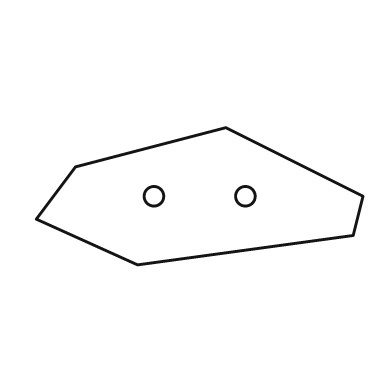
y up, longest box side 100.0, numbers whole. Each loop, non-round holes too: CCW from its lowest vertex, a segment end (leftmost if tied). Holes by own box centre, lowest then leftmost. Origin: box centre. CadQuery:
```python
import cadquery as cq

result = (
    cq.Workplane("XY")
    .moveTo(-19.0, -21.0)
    .lineTo(47.0, -12.0)
    .lineTo(50.0, 0.0)
    .lineTo(8.0, 21.0)
    .lineTo(-38.0, 9.0)
    .lineTo(-50.0, -7.0)
    .close()
    .moveTo(-14.0, 0.0)
    .circle(3.0)
    .moveTo(14.0, 0.0)
    .circle(3.0)
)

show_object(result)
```